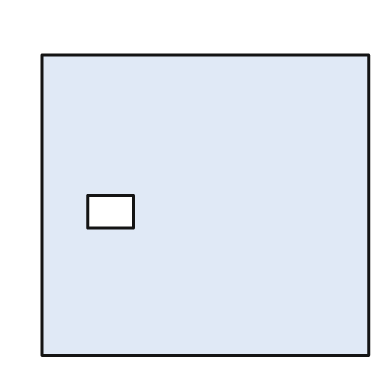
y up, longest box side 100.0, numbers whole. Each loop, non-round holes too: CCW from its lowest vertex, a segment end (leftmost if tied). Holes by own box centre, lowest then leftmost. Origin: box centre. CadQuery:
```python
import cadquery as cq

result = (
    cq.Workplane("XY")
    .moveTo(-50.0, -46.0)
    .lineTo(50.0, -46.0)
    .lineTo(50.0, 46.0)
    .lineTo(-50.0, 46.0)
    .close()
    .moveTo(-36.0, -7.0)
    .lineTo(-22.0, -7.0)
    .lineTo(-22.0, 3.0)
    .lineTo(-36.0, 3.0)
    .close()
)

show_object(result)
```